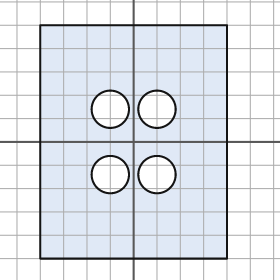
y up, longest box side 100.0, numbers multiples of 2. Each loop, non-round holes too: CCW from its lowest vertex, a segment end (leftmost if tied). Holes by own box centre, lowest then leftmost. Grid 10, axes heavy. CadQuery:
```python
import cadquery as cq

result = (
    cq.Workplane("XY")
    .moveTo(-40.0, -50.0)
    .lineTo(40.0, -50.0)
    .lineTo(40.0, 50.0)
    .lineTo(-40.0, 50.0)
    .close()
    .moveTo(-10.0, -14.0)
    .circle(8.0)
    .moveTo(10.0, -14.0)
    .circle(8.0)
    .moveTo(-10.0, 14.0)
    .circle(8.0)
    .moveTo(10.0, 14.0)
    .circle(8.0)
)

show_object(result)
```